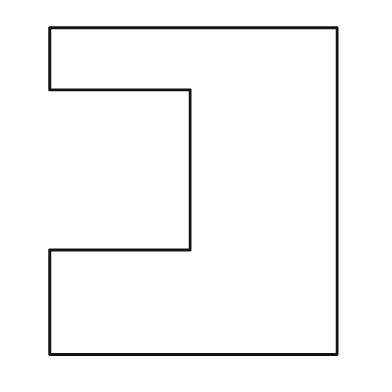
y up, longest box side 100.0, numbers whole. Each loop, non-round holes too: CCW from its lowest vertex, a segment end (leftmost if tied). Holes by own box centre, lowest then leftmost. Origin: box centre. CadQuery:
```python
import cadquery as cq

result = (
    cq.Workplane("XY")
    .moveTo(-44.0, -50.0)
    .lineTo(44.0, -50.0)
    .lineTo(44.0, 50.0)
    .lineTo(-44.0, 50.0)
    .lineTo(-44.0, 31.0)
    .lineTo(-1.0, 31.0)
    .lineTo(-1.0, -18.0)
    .lineTo(-44.0, -18.0)
    .close()
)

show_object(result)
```